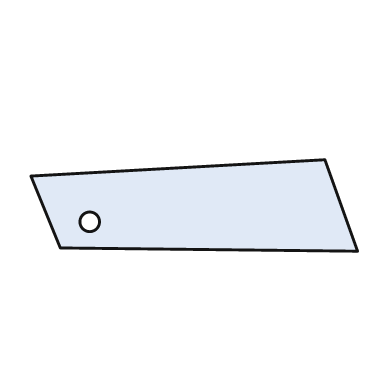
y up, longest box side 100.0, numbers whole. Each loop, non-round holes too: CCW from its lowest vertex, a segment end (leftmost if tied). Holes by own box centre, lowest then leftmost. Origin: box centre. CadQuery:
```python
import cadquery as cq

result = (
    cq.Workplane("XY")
    .moveTo(50.0, -14.0)
    .lineTo(40.0, 14.0)
    .lineTo(-50.0, 9.0)
    .lineTo(-41.0, -13.0)
    .close()
    .moveTo(-32.0, -5.0)
    .circle(3.0)
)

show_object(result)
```